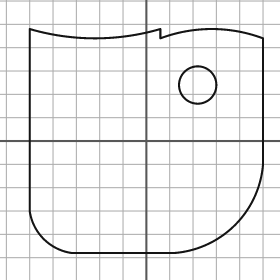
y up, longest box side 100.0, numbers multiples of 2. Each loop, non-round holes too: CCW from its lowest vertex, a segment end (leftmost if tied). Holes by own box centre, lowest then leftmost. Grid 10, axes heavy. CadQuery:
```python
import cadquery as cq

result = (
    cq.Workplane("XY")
    .moveTo(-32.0, -48.0)
    .lineTo(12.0, -48.0)
    .threePointArc((38.0, -36.0), (50.0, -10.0))
    .lineTo(50.0, 44.0)
    .threePointArc((28.0, 48.0), (6.0, 44.0))
    .lineTo(6.0, 48.0)
    .threePointArc((-22.0, 44.0), (-50.0, 48.0))
    .lineTo(-50.0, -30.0)
    .threePointArc((-44.0, -42.0), (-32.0, -48.0))
    .close()
    .moveTo(22.0, 24.0)
    .circle(8.0)
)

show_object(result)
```